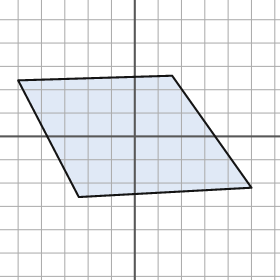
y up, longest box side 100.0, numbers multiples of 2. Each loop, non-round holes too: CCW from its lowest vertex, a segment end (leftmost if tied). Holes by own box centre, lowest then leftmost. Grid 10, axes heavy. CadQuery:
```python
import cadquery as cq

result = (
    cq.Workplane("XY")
    .moveTo(-24.0, -26.0)
    .lineTo(50.0, -22.0)
    .lineTo(16.0, 26.0)
    .lineTo(-50.0, 24.0)
    .close()
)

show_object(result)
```